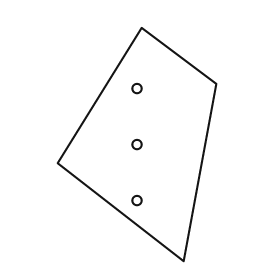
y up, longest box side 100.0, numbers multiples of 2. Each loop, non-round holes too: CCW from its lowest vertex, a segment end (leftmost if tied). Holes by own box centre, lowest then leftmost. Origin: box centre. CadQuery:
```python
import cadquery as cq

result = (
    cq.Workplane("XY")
    .moveTo(20.0, -50.0)
    .lineTo(34.0, 26.0)
    .lineTo(2.0, 50.0)
    .lineTo(-34.0, -8.0)
    .close()
    .moveTo(0.0, -24.0)
    .circle(2.0)
    .moveTo(0.0, 0.0)
    .circle(2.0)
    .moveTo(0.0, 24.0)
    .circle(2.0)
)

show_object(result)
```